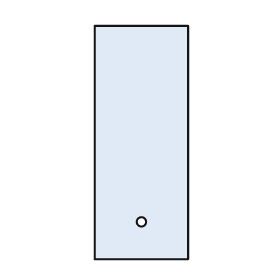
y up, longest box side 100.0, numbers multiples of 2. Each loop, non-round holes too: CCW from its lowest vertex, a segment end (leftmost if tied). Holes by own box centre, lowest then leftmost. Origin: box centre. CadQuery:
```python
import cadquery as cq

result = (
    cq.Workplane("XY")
    .moveTo(-20.0, -50.0)
    .lineTo(20.0, -50.0)
    .lineTo(20.0, 50.0)
    .lineTo(-20.0, 50.0)
    .close()
    .moveTo(0.0, -34.0)
    .circle(2.0)
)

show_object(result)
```